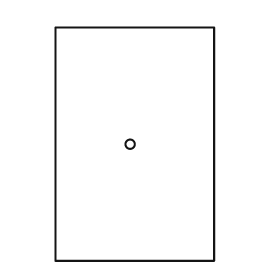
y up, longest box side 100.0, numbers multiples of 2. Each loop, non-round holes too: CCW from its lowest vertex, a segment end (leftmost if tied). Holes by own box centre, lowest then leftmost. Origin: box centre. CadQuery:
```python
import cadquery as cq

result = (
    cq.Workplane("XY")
    .moveTo(-34.0, -50.0)
    .lineTo(34.0, -50.0)
    .lineTo(34.0, 50.0)
    .lineTo(-34.0, 50.0)
    .close()
    .moveTo(-2.0, 0.0)
    .circle(2.0)
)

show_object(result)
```